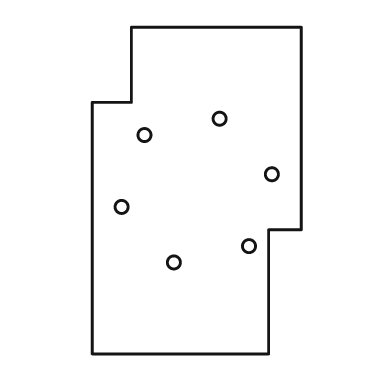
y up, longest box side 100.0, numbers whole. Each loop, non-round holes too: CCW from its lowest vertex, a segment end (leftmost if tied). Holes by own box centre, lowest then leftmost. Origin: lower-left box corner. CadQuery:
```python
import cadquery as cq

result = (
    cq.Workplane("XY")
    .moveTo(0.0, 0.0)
    .lineTo(54.0, 0.0)
    .lineTo(54.0, 38.0)
    .lineTo(64.0, 38.0)
    .lineTo(64.0, 100.0)
    .lineTo(12.0, 100.0)
    .lineTo(12.0, 77.0)
    .lineTo(0.0, 77.0)
    .close()
    .moveTo(25.0, 28.0)
    .circle(2.0)
    .moveTo(48.0, 33.0)
    .circle(2.0)
    .moveTo(9.0, 45.0)
    .circle(2.0)
    .moveTo(55.0, 55.0)
    .circle(2.0)
    .moveTo(16.0, 67.0)
    .circle(2.0)
    .moveTo(39.0, 72.0)
    .circle(2.0)
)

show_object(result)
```